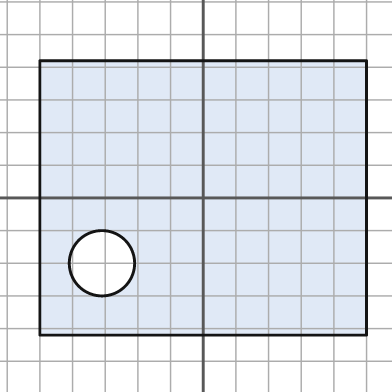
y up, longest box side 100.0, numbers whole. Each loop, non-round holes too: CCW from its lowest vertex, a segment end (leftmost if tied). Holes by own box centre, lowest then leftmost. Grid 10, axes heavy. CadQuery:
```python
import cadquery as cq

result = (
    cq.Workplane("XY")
    .moveTo(-50.0, -42.0)
    .lineTo(50.0, -42.0)
    .lineTo(50.0, 42.0)
    .lineTo(-50.0, 42.0)
    .close()
    .moveTo(-31.0, -20.0)
    .circle(10.0)
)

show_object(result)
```